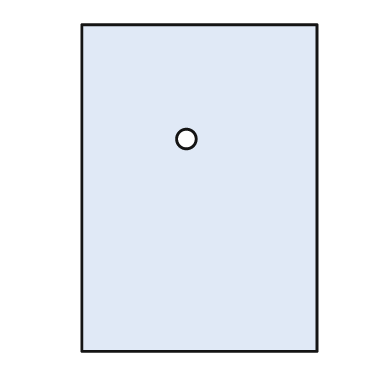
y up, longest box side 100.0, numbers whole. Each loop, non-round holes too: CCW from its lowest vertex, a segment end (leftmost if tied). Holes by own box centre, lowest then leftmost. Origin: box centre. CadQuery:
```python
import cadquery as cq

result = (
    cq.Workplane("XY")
    .moveTo(-36.0, -50.0)
    .lineTo(36.0, -50.0)
    .lineTo(36.0, 50.0)
    .lineTo(-36.0, 50.0)
    .close()
    .moveTo(-4.0, 15.0)
    .circle(3.0)
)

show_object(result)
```